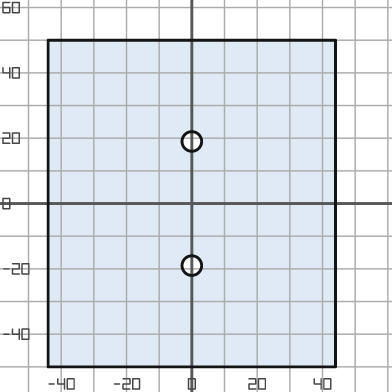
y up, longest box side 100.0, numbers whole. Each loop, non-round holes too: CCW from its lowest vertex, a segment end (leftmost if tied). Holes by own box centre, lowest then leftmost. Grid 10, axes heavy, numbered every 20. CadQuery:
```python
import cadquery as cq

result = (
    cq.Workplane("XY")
    .moveTo(-44.0, -50.0)
    .lineTo(44.0, -50.0)
    .lineTo(44.0, 50.0)
    .lineTo(-44.0, 50.0)
    .close()
    .moveTo(0.0, -19.0)
    .circle(3.0)
    .moveTo(0.0, 19.0)
    .circle(3.0)
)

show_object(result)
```